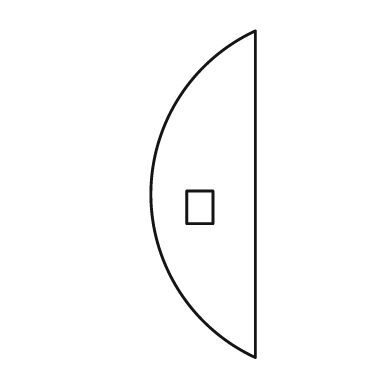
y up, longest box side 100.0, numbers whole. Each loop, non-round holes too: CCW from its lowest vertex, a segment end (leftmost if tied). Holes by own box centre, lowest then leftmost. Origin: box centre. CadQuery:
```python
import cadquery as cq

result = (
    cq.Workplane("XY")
    .moveTo(16.0, -50.0)
    .lineTo(16.0, 50.0)
    .threePointArc((-16.0, 0.0), (16.0, -50.0))
    .close()
    .moveTo(-5.0, -9.0)
    .lineTo(3.0, -9.0)
    .lineTo(3.0, 1.0)
    .lineTo(-5.0, 1.0)
    .close()
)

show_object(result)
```